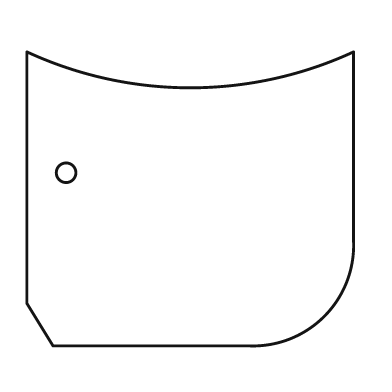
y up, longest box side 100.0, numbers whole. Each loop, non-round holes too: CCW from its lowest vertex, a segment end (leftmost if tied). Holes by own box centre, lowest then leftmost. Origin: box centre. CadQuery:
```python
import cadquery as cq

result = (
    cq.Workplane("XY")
    .moveTo(-42.0, -45.0)
    .lineTo(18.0, -45.0)
    .threePointArc((41.0, -36.0), (50.0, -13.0))
    .lineTo(50.0, 45.0)
    .threePointArc((0.0, 34.0), (-50.0, 45.0))
    .lineTo(-50.0, -32.0)
    .close()
    .moveTo(-38.0, 8.0)
    .circle(3.0)
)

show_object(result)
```